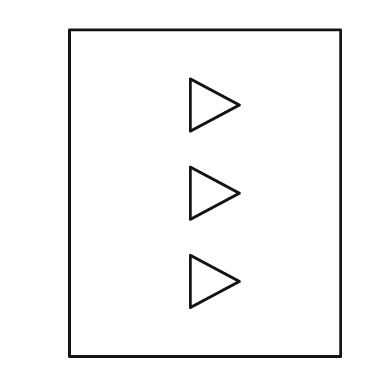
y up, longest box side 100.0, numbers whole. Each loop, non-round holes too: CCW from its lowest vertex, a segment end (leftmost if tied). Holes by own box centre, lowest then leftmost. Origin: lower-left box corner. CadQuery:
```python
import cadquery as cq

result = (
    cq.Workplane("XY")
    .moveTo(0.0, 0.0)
    .lineTo(83.0, 0.0)
    .lineTo(83.0, 100.0)
    .lineTo(0.0, 100.0)
    .close()
    .moveTo(37.0, 15.0)
    .lineTo(52.0, 23.0)
    .lineTo(37.0, 31.0)
    .close()
    .moveTo(37.0, 42.0)
    .lineTo(52.0, 50.0)
    .lineTo(37.0, 58.0)
    .close()
    .moveTo(37.0, 69.0)
    .lineTo(52.0, 77.0)
    .lineTo(37.0, 85.0)
    .close()
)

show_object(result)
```